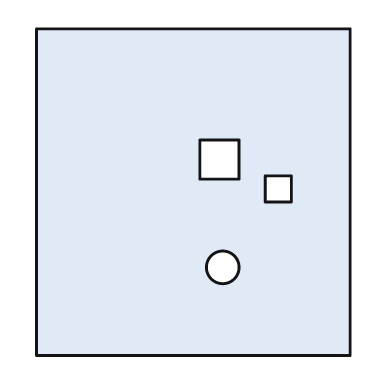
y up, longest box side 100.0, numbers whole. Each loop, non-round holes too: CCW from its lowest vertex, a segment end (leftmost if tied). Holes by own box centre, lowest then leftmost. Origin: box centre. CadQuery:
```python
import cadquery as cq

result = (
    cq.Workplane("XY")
    .moveTo(-48.0, -50.0)
    .lineTo(48.0, -50.0)
    .lineTo(48.0, 50.0)
    .lineTo(-48.0, 50.0)
    .close()
    .moveTo(9.0, -23.0)
    .circle(5.0)
    .moveTo(22.0, -3.0)
    .lineTo(30.0, -3.0)
    .lineTo(30.0, 5.0)
    .lineTo(22.0, 5.0)
    .close()
    .moveTo(2.0, 4.0)
    .lineTo(14.0, 4.0)
    .lineTo(14.0, 16.0)
    .lineTo(2.0, 16.0)
    .close()
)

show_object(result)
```